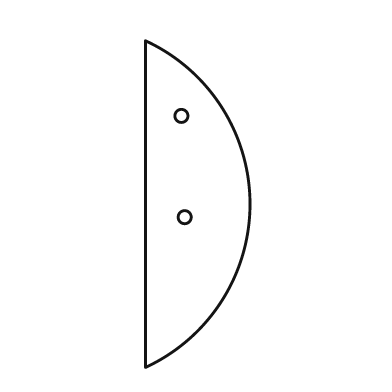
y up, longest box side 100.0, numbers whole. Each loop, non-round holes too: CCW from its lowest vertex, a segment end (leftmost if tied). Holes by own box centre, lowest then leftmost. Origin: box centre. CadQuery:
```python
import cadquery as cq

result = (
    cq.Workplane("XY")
    .moveTo(-16.0, -50.0)
    .threePointArc((16.0, 0.0), (-16.0, 50.0))
    .close()
    .moveTo(-4.0, -4.0)
    .circle(2.0)
    .moveTo(-5.0, 27.0)
    .circle(2.0)
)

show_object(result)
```